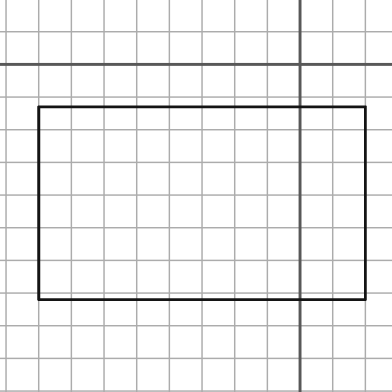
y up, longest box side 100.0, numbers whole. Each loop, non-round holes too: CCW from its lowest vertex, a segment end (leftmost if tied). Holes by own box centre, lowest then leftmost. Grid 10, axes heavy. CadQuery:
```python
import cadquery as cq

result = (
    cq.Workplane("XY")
    .moveTo(-80.0, -72.0)
    .lineTo(20.0, -72.0)
    .lineTo(20.0, -13.0)
    .lineTo(-80.0, -13.0)
    .close()
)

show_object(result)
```